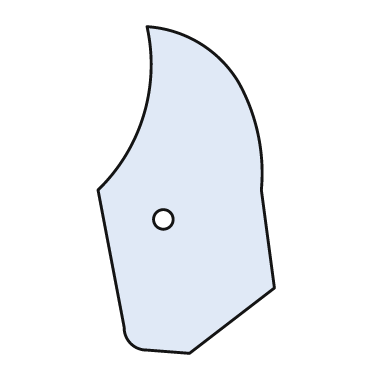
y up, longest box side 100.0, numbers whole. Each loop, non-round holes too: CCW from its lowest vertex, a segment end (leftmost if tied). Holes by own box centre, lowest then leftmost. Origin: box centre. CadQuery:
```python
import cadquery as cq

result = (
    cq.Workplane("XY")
    .moveTo(1.0, -50.0)
    .lineTo(27.0, -30.0)
    .lineTo(23.0, 0.0)
    .threePointArc((22.0, 17.0), (16.0, 33.0))
    .threePointArc((4.0, 45.0), (-12.0, 50.0))
    .threePointArc((-13.0, 23.0), (-27.0, 0.0))
    .lineTo(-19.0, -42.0)
    .threePointArc((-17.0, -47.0), (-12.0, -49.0))
    .close()
    .moveTo(-7.0, -9.0)
    .circle(3.0)
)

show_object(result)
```